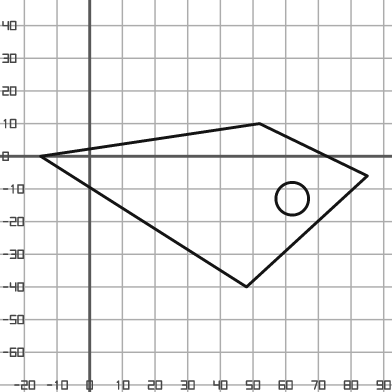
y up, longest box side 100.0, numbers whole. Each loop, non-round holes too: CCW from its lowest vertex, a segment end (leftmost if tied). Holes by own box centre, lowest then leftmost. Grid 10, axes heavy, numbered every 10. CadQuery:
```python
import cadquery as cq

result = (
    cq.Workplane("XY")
    .moveTo(48.0, -40.0)
    .lineTo(85.0, -6.0)
    .lineTo(52.0, 10.0)
    .lineTo(-15.0, 0.0)
    .close()
    .moveTo(62.0, -13.0)
    .circle(5.0)
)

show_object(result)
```